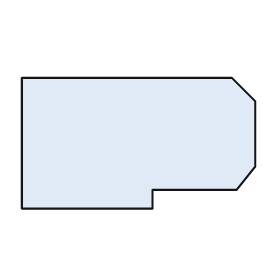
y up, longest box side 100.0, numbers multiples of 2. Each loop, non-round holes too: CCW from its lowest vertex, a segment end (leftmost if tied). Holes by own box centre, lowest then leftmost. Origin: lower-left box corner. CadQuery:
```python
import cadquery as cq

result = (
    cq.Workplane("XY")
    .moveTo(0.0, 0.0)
    .lineTo(56.0, 0.0)
    .lineTo(56.0, 8.0)
    .lineTo(92.0, 8.0)
    .lineTo(100.0, 18.0)
    .lineTo(100.0, 46.0)
    .lineTo(90.0, 56.0)
    .lineTo(0.0, 56.0)
    .close()
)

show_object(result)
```